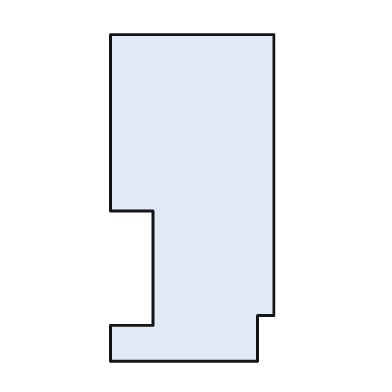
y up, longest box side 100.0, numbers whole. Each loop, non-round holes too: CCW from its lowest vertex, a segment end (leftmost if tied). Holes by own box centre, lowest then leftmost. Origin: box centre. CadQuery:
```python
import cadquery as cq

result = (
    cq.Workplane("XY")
    .moveTo(-25.0, -50.0)
    .lineTo(20.0, -50.0)
    .lineTo(20.0, -36.0)
    .lineTo(25.0, -36.0)
    .lineTo(25.0, 50.0)
    .lineTo(-25.0, 50.0)
    .lineTo(-25.0, -4.0)
    .lineTo(-12.0, -4.0)
    .lineTo(-12.0, -39.0)
    .lineTo(-25.0, -39.0)
    .close()
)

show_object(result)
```